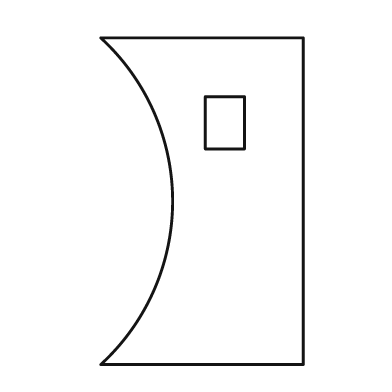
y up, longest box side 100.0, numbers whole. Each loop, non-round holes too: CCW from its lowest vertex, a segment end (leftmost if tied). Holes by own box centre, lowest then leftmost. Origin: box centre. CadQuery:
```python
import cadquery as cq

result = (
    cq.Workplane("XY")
    .moveTo(-31.0, -50.0)
    .lineTo(31.0, -50.0)
    .lineTo(31.0, 50.0)
    .lineTo(-31.0, 50.0)
    .threePointArc((-9.0, 0.0), (-31.0, -50.0))
    .close()
    .moveTo(1.0, 16.0)
    .lineTo(13.0, 16.0)
    .lineTo(13.0, 32.0)
    .lineTo(1.0, 32.0)
    .close()
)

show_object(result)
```